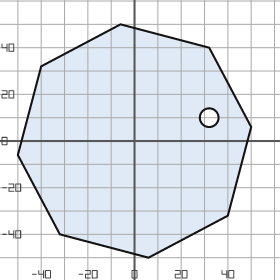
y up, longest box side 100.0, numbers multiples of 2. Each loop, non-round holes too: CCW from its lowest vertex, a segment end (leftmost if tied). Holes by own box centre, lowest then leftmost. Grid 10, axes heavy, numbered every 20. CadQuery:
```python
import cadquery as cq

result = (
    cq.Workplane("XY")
    .moveTo(6.0, -50.0)
    .lineTo(40.0, -32.0)
    .lineTo(50.0, 6.0)
    .lineTo(32.0, 40.0)
    .lineTo(-6.0, 50.0)
    .lineTo(-40.0, 32.0)
    .lineTo(-50.0, -6.0)
    .lineTo(-32.0, -40.0)
    .close()
    .moveTo(32.0, 10.0)
    .circle(4.0)
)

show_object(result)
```